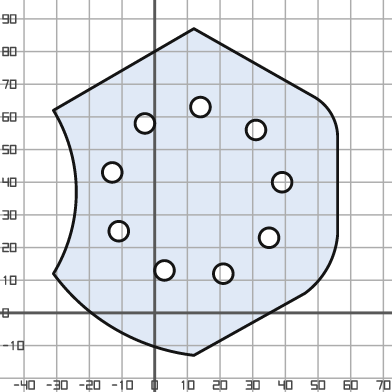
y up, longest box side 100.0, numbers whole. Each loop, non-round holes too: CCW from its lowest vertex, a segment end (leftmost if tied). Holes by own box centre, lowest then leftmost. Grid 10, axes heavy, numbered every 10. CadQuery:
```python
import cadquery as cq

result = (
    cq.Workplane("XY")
    .moveTo(12.0, -13.0)
    .lineTo(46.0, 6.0)
    .threePointArc((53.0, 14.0), (56.0, 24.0))
    .lineTo(56.0, 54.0)
    .threePointArc((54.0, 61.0), (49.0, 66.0))
    .lineTo(12.0, 87.0)
    .lineTo(-31.0, 62.0)
    .threePointArc((-24.0, 37.0), (-31.0, 12.0))
    .threePointArc((-12.0, -5.0), (12.0, -13.0))
    .close()
    .moveTo(21.0, 12.0)
    .circle(3.0)
    .moveTo(3.0, 13.0)
    .circle(3.0)
    .moveTo(35.0, 23.0)
    .circle(3.0)
    .moveTo(-11.0, 25.0)
    .circle(3.0)
    .moveTo(39.0, 40.0)
    .circle(3.0)
    .moveTo(-13.0, 43.0)
    .circle(3.0)
    .moveTo(31.0, 56.0)
    .circle(3.0)
    .moveTo(-3.0, 58.0)
    .circle(3.0)
    .moveTo(14.0, 63.0)
    .circle(3.0)
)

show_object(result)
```